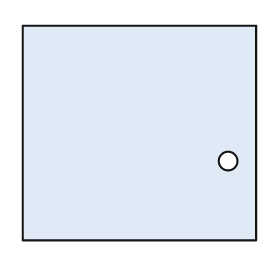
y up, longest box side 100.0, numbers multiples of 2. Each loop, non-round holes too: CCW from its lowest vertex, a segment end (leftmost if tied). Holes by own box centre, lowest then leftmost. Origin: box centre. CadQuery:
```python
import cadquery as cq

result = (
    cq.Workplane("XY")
    .moveTo(-50.0, -46.0)
    .lineTo(50.0, -46.0)
    .lineTo(50.0, 46.0)
    .lineTo(-50.0, 46.0)
    .close()
    .moveTo(38.0, -12.0)
    .circle(4.0)
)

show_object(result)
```